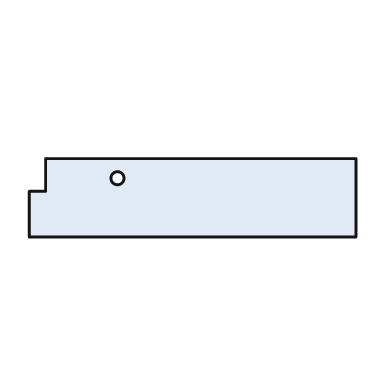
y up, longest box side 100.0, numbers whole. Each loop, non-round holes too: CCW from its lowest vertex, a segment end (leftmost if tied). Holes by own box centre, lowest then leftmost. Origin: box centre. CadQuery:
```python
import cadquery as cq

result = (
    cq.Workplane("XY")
    .moveTo(-50.0, -12.0)
    .lineTo(50.0, -12.0)
    .lineTo(50.0, 12.0)
    .lineTo(-45.0, 12.0)
    .lineTo(-45.0, 2.0)
    .lineTo(-50.0, 2.0)
    .close()
    .moveTo(-23.0, 6.0)
    .circle(2.0)
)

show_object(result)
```